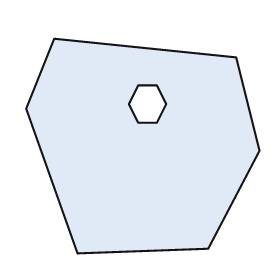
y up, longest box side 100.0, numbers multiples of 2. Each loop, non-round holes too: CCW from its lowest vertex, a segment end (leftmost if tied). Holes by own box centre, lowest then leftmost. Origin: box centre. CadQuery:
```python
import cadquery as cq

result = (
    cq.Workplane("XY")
    .moveTo(-28.0, -46.0)
    .lineTo(28.0, -44.0)
    .lineTo(50.0, -2.0)
    .lineTo(40.0, 38.0)
    .lineTo(-38.0, 46.0)
    .lineTo(-50.0, 16.0)
    .close()
    .moveTo(-2.0, 10.0)
    .lineTo(6.0, 10.0)
    .lineTo(10.0, 18.0)
    .lineTo(6.0, 26.0)
    .lineTo(-2.0, 26.0)
    .lineTo(-6.0, 18.0)
    .close()
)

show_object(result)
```